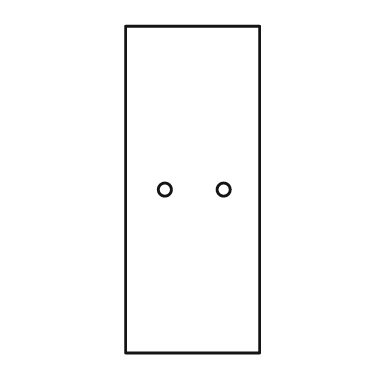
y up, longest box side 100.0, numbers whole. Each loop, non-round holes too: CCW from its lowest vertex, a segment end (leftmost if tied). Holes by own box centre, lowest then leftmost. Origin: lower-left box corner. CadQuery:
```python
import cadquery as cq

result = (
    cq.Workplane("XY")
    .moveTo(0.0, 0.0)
    .lineTo(41.0, 0.0)
    .lineTo(41.0, 100.0)
    .lineTo(0.0, 100.0)
    .close()
    .moveTo(12.0, 50.0)
    .circle(2.0)
    .moveTo(30.0, 50.0)
    .circle(2.0)
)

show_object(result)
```